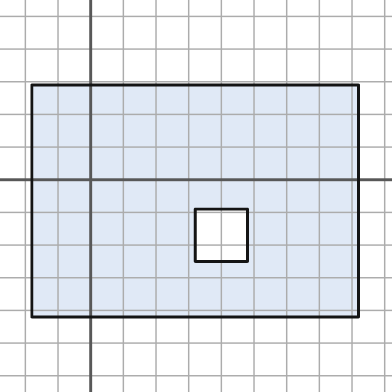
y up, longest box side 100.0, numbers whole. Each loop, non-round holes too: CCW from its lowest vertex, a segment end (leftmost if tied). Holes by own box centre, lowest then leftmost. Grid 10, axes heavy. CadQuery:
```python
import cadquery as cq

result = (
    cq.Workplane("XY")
    .moveTo(-18.0, -42.0)
    .lineTo(82.0, -42.0)
    .lineTo(82.0, 29.0)
    .lineTo(-18.0, 29.0)
    .close()
    .moveTo(32.0, -25.0)
    .lineTo(48.0, -25.0)
    .lineTo(48.0, -9.0)
    .lineTo(32.0, -9.0)
    .close()
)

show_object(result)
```